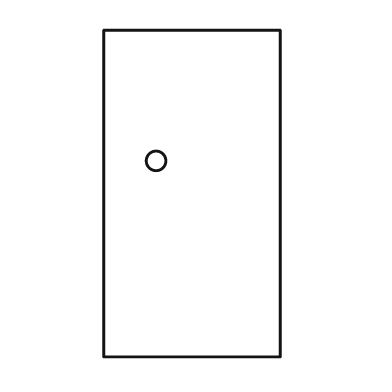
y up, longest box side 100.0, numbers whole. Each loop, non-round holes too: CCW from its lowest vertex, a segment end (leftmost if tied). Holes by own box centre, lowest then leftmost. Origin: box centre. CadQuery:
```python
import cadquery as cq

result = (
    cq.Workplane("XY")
    .moveTo(-27.0, -50.0)
    .lineTo(27.0, -50.0)
    .lineTo(27.0, 50.0)
    .lineTo(-27.0, 50.0)
    .close()
    .moveTo(-11.0, 10.0)
    .circle(3.0)
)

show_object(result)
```